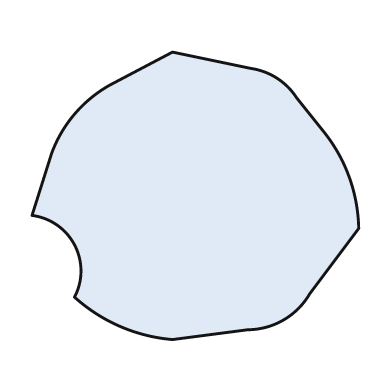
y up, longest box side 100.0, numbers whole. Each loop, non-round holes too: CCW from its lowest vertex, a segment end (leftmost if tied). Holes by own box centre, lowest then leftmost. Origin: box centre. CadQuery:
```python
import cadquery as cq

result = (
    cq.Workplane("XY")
    .moveTo(-7.0, -44.0)
    .lineTo(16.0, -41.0)
    .threePointArc((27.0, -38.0), (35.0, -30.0))
    .lineTo(50.0, -10.0)
    .threePointArc((47.0, 6.0), (39.0, 20.0))
    .lineTo(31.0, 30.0)
    .threePointArc((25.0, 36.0), (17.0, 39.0))
    .lineTo(-7.0, 44.0)
    .lineTo(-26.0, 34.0)
    .threePointArc((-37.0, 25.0), (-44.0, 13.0))
    .lineTo(-50.0, -6.0)
    .threePointArc((-37.0, -15.0), (-37.0, -31.0))
    .threePointArc((-23.0, -40.0), (-7.0, -44.0))
    .close()
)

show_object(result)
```